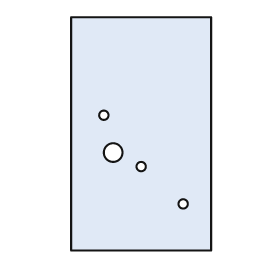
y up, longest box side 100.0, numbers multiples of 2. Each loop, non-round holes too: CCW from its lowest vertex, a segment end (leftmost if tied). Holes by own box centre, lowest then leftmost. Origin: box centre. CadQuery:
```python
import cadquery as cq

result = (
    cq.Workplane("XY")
    .moveTo(-30.0, -50.0)
    .lineTo(30.0, -50.0)
    .lineTo(30.0, 50.0)
    .lineTo(-30.0, 50.0)
    .close()
    .moveTo(18.0, -30.0)
    .circle(2.0)
    .moveTo(0.0, -14.0)
    .circle(2.0)
    .moveTo(-12.0, -8.0)
    .circle(4.0)
    .moveTo(-16.0, 8.0)
    .circle(2.0)
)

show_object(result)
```